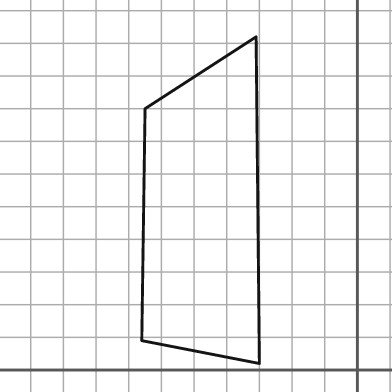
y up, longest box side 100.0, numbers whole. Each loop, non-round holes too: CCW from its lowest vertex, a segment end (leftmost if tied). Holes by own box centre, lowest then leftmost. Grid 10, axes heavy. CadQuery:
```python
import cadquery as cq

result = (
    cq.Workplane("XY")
    .moveTo(-30.0, 2.0)
    .lineTo(-31.0, 102.0)
    .lineTo(-65.0, 80.0)
    .lineTo(-66.0, 9.0)
    .close()
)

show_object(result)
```